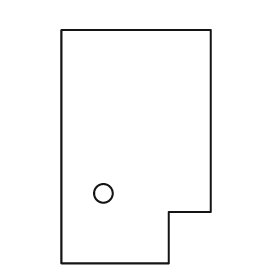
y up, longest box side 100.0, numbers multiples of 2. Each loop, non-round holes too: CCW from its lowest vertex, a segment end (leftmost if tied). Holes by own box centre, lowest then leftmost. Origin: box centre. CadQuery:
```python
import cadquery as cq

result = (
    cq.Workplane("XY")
    .moveTo(-32.0, -50.0)
    .lineTo(14.0, -50.0)
    .lineTo(14.0, -28.0)
    .lineTo(32.0, -28.0)
    .lineTo(32.0, 50.0)
    .lineTo(-32.0, 50.0)
    .close()
    .moveTo(-14.0, -20.0)
    .circle(4.0)
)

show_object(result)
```